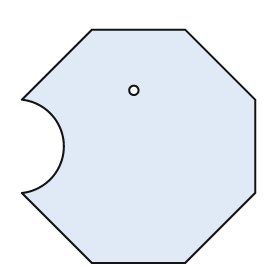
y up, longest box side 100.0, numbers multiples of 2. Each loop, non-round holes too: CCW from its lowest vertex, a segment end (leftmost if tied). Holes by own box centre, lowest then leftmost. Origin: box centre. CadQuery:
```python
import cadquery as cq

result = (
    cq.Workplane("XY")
    .moveTo(-20.0, -50.0)
    .lineTo(20.0, -50.0)
    .lineTo(50.0, -20.0)
    .lineTo(50.0, 20.0)
    .lineTo(20.0, 50.0)
    .lineTo(-20.0, 50.0)
    .lineTo(-50.0, 20.0)
    .threePointArc((-32.0, 0.0), (-50.0, -20.0))
    .close()
    .moveTo(-2.0, 24.0)
    .circle(2.0)
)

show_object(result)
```